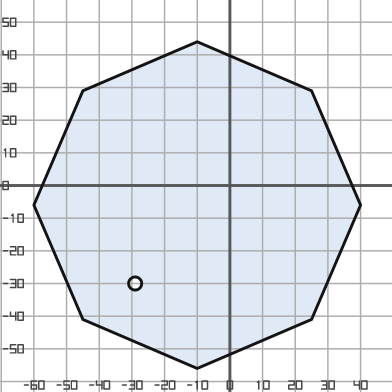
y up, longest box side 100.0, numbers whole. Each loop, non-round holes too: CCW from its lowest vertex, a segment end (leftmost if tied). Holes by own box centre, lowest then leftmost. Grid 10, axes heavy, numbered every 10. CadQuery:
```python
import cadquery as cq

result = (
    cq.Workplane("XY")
    .moveTo(-10.0, -56.0)
    .lineTo(25.0, -41.0)
    .lineTo(40.0, -6.0)
    .lineTo(25.0, 29.0)
    .lineTo(-10.0, 44.0)
    .lineTo(-45.0, 29.0)
    .lineTo(-60.0, -6.0)
    .lineTo(-45.0, -41.0)
    .close()
    .moveTo(-29.0, -30.0)
    .circle(2.0)
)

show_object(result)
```